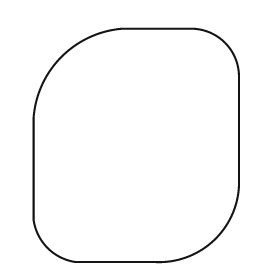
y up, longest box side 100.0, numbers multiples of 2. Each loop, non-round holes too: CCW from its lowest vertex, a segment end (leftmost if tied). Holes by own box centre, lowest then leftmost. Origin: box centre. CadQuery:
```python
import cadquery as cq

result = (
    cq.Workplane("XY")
    .moveTo(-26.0, -50.0)
    .lineTo(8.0, -50.0)
    .threePointArc((34.0, -40.0), (44.0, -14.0))
    .lineTo(44.0, 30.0)
    .threePointArc((38.0, 44.0), (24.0, 50.0))
    .lineTo(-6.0, 50.0)
    .threePointArc((-32.0, 38.0), (-44.0, 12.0))
    .lineTo(-44.0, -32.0)
    .threePointArc((-38.0, -44.0), (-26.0, -50.0))
    .close()
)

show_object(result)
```